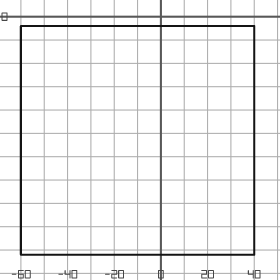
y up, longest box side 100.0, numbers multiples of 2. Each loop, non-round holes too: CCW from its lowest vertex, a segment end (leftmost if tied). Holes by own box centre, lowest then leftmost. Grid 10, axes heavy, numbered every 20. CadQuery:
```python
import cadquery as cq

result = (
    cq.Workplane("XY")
    .moveTo(-60.0, -102.0)
    .lineTo(40.0, -102.0)
    .lineTo(40.0, -4.0)
    .lineTo(-60.0, -4.0)
    .close()
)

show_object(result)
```